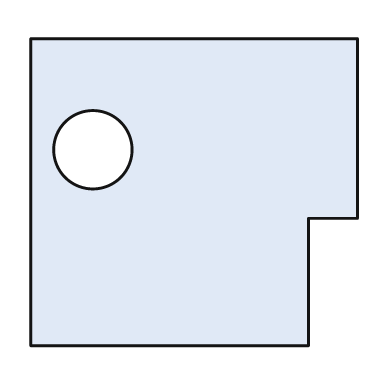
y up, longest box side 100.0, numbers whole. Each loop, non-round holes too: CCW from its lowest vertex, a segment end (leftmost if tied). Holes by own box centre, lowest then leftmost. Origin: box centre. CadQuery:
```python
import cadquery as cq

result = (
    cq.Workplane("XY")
    .moveTo(-50.0, -47.0)
    .lineTo(35.0, -47.0)
    .lineTo(35.0, -8.0)
    .lineTo(50.0, -8.0)
    .lineTo(50.0, 47.0)
    .lineTo(-50.0, 47.0)
    .close()
    .moveTo(-31.0, 13.0)
    .circle(12.0)
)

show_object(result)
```